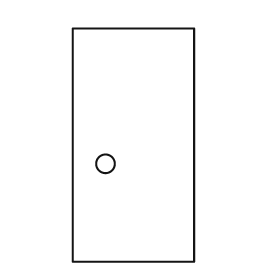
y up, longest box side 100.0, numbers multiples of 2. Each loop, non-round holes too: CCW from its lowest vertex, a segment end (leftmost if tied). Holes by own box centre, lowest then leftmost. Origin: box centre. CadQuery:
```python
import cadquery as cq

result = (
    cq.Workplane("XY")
    .moveTo(-26.0, -50.0)
    .lineTo(26.0, -50.0)
    .lineTo(26.0, 50.0)
    .lineTo(-26.0, 50.0)
    .close()
    .moveTo(-12.0, -8.0)
    .circle(4.0)
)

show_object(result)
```